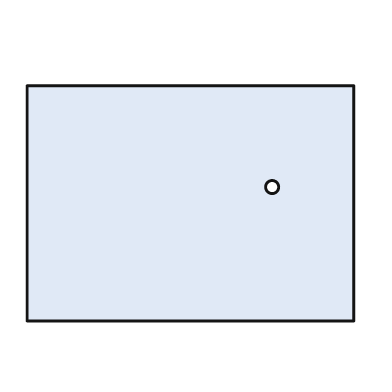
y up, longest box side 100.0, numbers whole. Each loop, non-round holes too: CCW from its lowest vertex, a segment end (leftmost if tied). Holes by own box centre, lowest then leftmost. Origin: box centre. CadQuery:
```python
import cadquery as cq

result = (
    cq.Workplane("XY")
    .moveTo(-50.0, -36.0)
    .lineTo(50.0, -36.0)
    .lineTo(50.0, 36.0)
    .lineTo(-50.0, 36.0)
    .close()
    .moveTo(25.0, 5.0)
    .circle(2.0)
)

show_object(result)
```